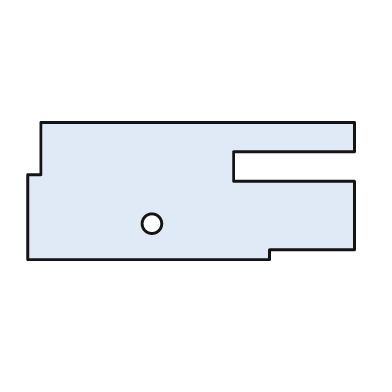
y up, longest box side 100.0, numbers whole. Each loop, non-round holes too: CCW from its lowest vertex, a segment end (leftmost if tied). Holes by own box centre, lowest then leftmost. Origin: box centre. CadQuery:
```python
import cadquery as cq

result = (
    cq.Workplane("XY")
    .moveTo(-50.0, -21.0)
    .lineTo(24.0, -21.0)
    .lineTo(24.0, -18.0)
    .lineTo(50.0, -18.0)
    .lineTo(50.0, 3.0)
    .lineTo(13.0, 3.0)
    .lineTo(13.0, 12.0)
    .lineTo(50.0, 12.0)
    .lineTo(50.0, 21.0)
    .lineTo(-46.0, 21.0)
    .lineTo(-46.0, 5.0)
    .lineTo(-50.0, 5.0)
    .close()
    .moveTo(-12.0, -10.0)
    .circle(3.0)
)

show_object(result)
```